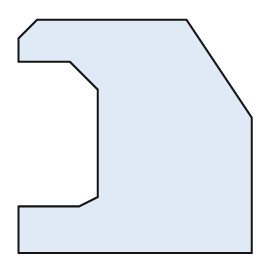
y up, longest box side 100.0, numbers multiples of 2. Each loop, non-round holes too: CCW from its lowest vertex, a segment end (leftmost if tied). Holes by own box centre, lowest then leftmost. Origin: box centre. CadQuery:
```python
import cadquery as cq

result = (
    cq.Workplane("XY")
    .moveTo(-50.0, -50.0)
    .lineTo(50.0, -50.0)
    .lineTo(50.0, 8.0)
    .lineTo(22.0, 50.0)
    .lineTo(-42.0, 50.0)
    .lineTo(-50.0, 42.0)
    .lineTo(-50.0, 32.0)
    .lineTo(-28.0, 32.0)
    .lineTo(-16.0, 20.0)
    .lineTo(-16.0, -26.0)
    .lineTo(-24.0, -30.0)
    .lineTo(-50.0, -30.0)
    .close()
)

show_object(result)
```